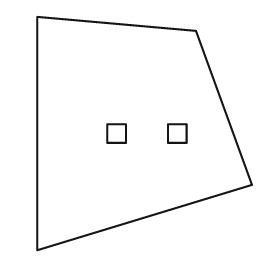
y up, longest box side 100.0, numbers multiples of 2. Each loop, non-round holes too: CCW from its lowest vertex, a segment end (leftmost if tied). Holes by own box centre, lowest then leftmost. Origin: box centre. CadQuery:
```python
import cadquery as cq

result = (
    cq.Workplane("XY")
    .moveTo(-46.0, -50.0)
    .lineTo(46.0, -22.0)
    .lineTo(22.0, 44.0)
    .lineTo(-46.0, 50.0)
    .close()
    .moveTo(-16.0, -4.0)
    .lineTo(-8.0, -4.0)
    .lineTo(-8.0, 4.0)
    .lineTo(-16.0, 4.0)
    .close()
    .moveTo(10.0, -4.0)
    .lineTo(18.0, -4.0)
    .lineTo(18.0, 4.0)
    .lineTo(10.0, 4.0)
    .close()
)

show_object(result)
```